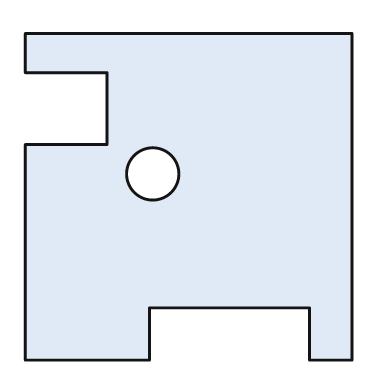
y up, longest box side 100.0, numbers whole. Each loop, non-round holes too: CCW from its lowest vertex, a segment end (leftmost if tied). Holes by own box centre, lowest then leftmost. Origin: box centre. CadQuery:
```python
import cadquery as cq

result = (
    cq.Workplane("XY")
    .moveTo(-50.0, -50.0)
    .lineTo(-12.0, -50.0)
    .lineTo(-12.0, -34.0)
    .lineTo(37.0, -34.0)
    .lineTo(37.0, -50.0)
    .lineTo(50.0, -50.0)
    .lineTo(50.0, 50.0)
    .lineTo(-50.0, 50.0)
    .lineTo(-50.0, 38.0)
    .lineTo(-25.0, 38.0)
    .lineTo(-25.0, 16.0)
    .lineTo(-50.0, 16.0)
    .close()
    .moveTo(-11.0, 7.0)
    .circle(8.0)
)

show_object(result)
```